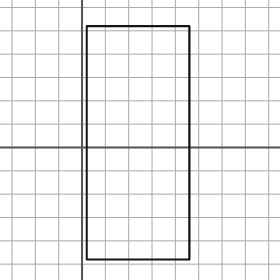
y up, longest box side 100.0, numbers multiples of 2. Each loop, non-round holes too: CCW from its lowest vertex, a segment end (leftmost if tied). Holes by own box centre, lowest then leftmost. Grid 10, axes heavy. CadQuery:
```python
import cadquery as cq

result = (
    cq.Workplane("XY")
    .moveTo(2.0, -48.0)
    .lineTo(46.0, -48.0)
    .lineTo(46.0, 52.0)
    .lineTo(2.0, 52.0)
    .close()
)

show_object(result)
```